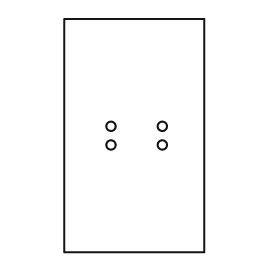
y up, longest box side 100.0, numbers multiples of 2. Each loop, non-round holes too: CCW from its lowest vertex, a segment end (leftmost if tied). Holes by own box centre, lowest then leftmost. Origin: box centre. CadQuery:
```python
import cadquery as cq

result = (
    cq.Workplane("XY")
    .moveTo(-30.0, -50.0)
    .lineTo(30.0, -50.0)
    .lineTo(30.0, 50.0)
    .lineTo(-30.0, 50.0)
    .close()
    .moveTo(-10.0, -4.0)
    .circle(2.0)
    .moveTo(12.0, -4.0)
    .circle(2.0)
    .moveTo(-10.0, 4.0)
    .circle(2.0)
    .moveTo(12.0, 4.0)
    .circle(2.0)
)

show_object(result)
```